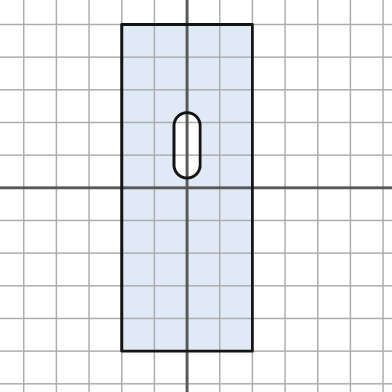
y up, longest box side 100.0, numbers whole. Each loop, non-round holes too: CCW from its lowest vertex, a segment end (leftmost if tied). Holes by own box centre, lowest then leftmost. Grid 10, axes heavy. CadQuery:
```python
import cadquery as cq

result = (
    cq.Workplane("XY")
    .moveTo(-20.0, -50.0)
    .lineTo(20.0, -50.0)
    .lineTo(20.0, 50.0)
    .lineTo(-20.0, 50.0)
    .close()
    .moveTo(-4.0, 7.0)
    .threePointArc((0.0, 3.0), (4.0, 7.0))
    .lineTo(4.0, 19.0)
    .threePointArc((0.0, 23.0), (-4.0, 19.0))
    .close()
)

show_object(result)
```